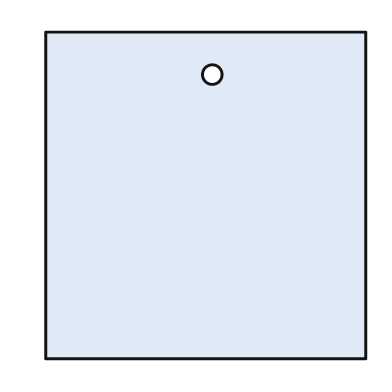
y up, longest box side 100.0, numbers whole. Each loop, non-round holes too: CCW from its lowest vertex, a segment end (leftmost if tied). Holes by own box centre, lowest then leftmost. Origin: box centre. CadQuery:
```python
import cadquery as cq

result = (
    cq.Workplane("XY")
    .moveTo(-49.0, -50.0)
    .lineTo(49.0, -50.0)
    .lineTo(49.0, 50.0)
    .lineTo(-49.0, 50.0)
    .close()
    .moveTo(2.0, 37.0)
    .circle(3.0)
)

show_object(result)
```